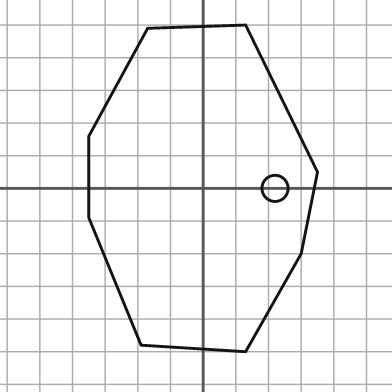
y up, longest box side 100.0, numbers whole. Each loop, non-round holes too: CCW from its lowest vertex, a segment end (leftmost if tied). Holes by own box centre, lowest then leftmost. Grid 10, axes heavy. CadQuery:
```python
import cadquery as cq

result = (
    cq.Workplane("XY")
    .moveTo(13.0, -50.0)
    .lineTo(30.0, -20.0)
    .lineTo(35.0, 5.0)
    .lineTo(13.0, 50.0)
    .lineTo(-17.0, 49.0)
    .lineTo(-35.0, 16.0)
    .lineTo(-35.0, -9.0)
    .lineTo(-19.0, -48.0)
    .close()
    .moveTo(22.0, 0.0)
    .circle(4.0)
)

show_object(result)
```